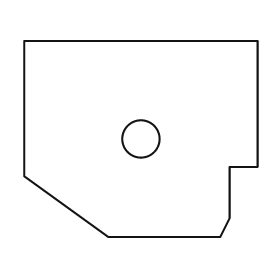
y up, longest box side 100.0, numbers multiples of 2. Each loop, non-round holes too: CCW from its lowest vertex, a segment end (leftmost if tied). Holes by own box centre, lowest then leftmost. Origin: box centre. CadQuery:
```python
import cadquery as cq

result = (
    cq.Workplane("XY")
    .moveTo(-14.0, -42.0)
    .lineTo(34.0, -42.0)
    .lineTo(38.0, -34.0)
    .lineTo(38.0, -12.0)
    .lineTo(50.0, -12.0)
    .lineTo(50.0, 42.0)
    .lineTo(-50.0, 42.0)
    .lineTo(-50.0, -16.0)
    .close()
    .moveTo(0.0, 0.0)
    .circle(8.0)
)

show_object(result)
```